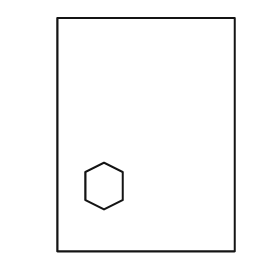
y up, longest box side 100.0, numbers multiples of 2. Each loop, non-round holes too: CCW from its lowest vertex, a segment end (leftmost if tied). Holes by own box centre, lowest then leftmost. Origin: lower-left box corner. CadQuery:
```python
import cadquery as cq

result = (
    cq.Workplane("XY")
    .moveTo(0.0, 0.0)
    .lineTo(76.0, 0.0)
    .lineTo(76.0, 100.0)
    .lineTo(0.0, 100.0)
    .close()
    .moveTo(20.0, 18.0)
    .lineTo(28.0, 22.0)
    .lineTo(28.0, 34.0)
    .lineTo(20.0, 38.0)
    .lineTo(12.0, 34.0)
    .lineTo(12.0, 22.0)
    .close()
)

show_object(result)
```